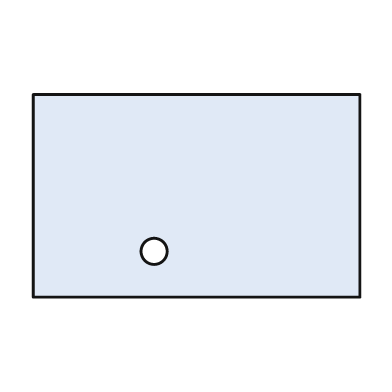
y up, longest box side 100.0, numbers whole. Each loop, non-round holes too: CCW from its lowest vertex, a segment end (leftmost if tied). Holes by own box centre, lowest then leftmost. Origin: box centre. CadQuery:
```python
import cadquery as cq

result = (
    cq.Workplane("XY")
    .moveTo(-50.0, -31.0)
    .lineTo(50.0, -31.0)
    .lineTo(50.0, 31.0)
    .lineTo(-50.0, 31.0)
    .close()
    .moveTo(-13.0, -17.0)
    .circle(4.0)
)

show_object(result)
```